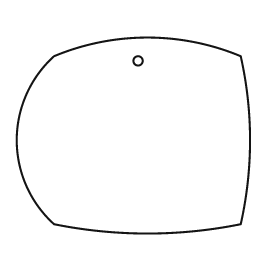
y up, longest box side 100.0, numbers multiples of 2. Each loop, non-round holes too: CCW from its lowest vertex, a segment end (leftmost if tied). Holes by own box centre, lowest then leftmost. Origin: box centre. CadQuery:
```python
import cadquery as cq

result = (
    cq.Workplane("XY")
    .moveTo(-34.0, -38.0)
    .threePointArc((6.0, -42.0), (46.0, -38.0))
    .threePointArc((50.0, -2.0), (46.0, 34.0))
    .threePointArc((6.0, 42.0), (-34.0, 34.0))
    .threePointArc((-50.0, -2.0), (-34.0, -38.0))
    .close()
    .moveTo(2.0, 32.0)
    .circle(2.0)
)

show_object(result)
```